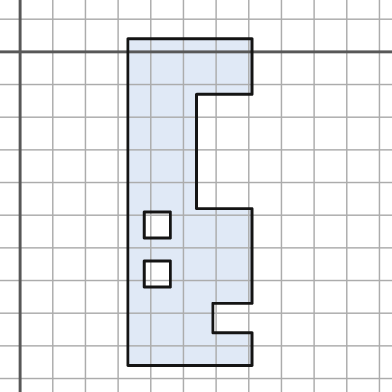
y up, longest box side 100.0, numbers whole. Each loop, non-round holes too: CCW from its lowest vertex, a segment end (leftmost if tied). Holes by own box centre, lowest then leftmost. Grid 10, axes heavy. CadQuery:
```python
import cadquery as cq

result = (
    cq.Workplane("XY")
    .moveTo(33.0, -96.0)
    .lineTo(71.0, -96.0)
    .lineTo(71.0, -86.0)
    .lineTo(59.0, -86.0)
    .lineTo(59.0, -77.0)
    .lineTo(71.0, -77.0)
    .lineTo(71.0, -48.0)
    .lineTo(54.0, -48.0)
    .lineTo(54.0, -13.0)
    .lineTo(71.0, -13.0)
    .lineTo(71.0, 4.0)
    .lineTo(33.0, 4.0)
    .close()
    .moveTo(38.0, -72.0)
    .lineTo(46.0, -72.0)
    .lineTo(46.0, -64.0)
    .lineTo(38.0, -64.0)
    .close()
    .moveTo(38.0, -57.0)
    .lineTo(46.0, -57.0)
    .lineTo(46.0, -49.0)
    .lineTo(38.0, -49.0)
    .close()
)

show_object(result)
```